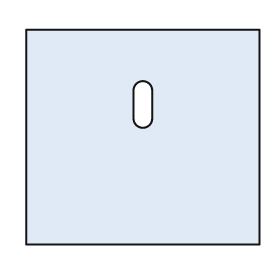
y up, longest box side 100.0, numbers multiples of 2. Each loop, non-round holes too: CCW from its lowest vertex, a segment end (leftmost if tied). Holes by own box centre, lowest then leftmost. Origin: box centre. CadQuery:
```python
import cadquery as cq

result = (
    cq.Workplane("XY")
    .moveTo(-50.0, -46.0)
    .lineTo(50.0, -46.0)
    .lineTo(50.0, 46.0)
    .lineTo(-50.0, 46.0)
    .close()
    .moveTo(-4.0, 8.0)
    .threePointArc((0.0, 4.0), (4.0, 8.0))
    .lineTo(4.0, 20.0)
    .threePointArc((0.0, 24.0), (-4.0, 20.0))
    .close()
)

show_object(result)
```